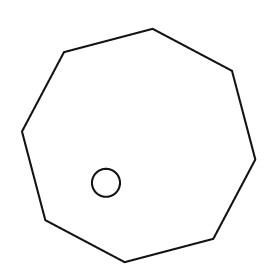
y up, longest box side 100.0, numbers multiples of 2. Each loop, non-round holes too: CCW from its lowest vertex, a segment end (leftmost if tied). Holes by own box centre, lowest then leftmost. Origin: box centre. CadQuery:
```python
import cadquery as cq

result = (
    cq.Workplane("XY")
    .moveTo(-6.0, -50.0)
    .lineTo(32.0, -40.0)
    .lineTo(50.0, -6.0)
    .lineTo(40.0, 32.0)
    .lineTo(6.0, 50.0)
    .lineTo(-32.0, 40.0)
    .lineTo(-50.0, 6.0)
    .lineTo(-40.0, -32.0)
    .close()
    .moveTo(-14.0, -16.0)
    .circle(6.0)
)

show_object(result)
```